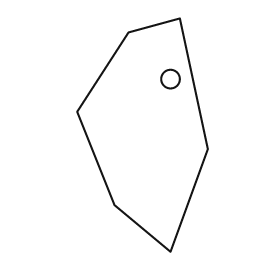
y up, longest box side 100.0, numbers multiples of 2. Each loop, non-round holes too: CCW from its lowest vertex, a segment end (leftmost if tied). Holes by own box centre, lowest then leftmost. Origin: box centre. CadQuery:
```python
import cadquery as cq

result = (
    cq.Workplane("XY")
    .moveTo(12.0, -50.0)
    .lineTo(28.0, -6.0)
    .lineTo(16.0, 50.0)
    .lineTo(-6.0, 44.0)
    .lineTo(-28.0, 10.0)
    .lineTo(-12.0, -30.0)
    .close()
    .moveTo(12.0, 24.0)
    .circle(4.0)
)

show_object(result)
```